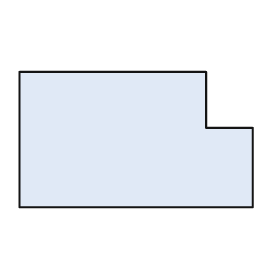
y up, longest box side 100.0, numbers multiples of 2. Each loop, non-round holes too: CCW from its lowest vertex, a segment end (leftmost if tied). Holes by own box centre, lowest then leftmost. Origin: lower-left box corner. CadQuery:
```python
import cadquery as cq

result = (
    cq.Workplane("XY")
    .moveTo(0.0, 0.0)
    .lineTo(100.0, 0.0)
    .lineTo(100.0, 34.0)
    .lineTo(80.0, 34.0)
    .lineTo(80.0, 58.0)
    .lineTo(0.0, 58.0)
    .close()
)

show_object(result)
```